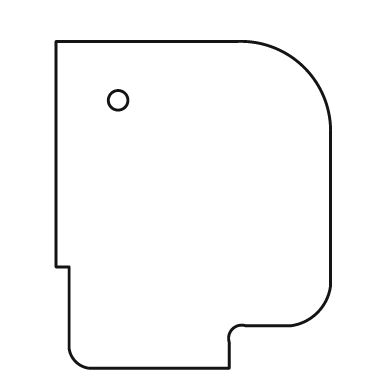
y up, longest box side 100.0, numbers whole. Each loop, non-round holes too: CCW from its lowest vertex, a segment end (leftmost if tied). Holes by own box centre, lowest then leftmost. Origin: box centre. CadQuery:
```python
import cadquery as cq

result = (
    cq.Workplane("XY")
    .moveTo(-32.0, -50.0)
    .lineTo(11.0, -50.0)
    .lineTo(11.0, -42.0)
    .threePointArc((12.0, -38.0), (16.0, -37.0))
    .lineTo(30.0, -37.0)
    .threePointArc((38.0, -33.0), (42.0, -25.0))
    .lineTo(42.0, 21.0)
    .threePointArc((34.0, 42.0), (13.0, 50.0))
    .lineTo(-42.0, 50.0)
    .lineTo(-42.0, -19.0)
    .lineTo(-38.0, -19.0)
    .lineTo(-38.0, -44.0)
    .threePointArc((-36.0, -48.0), (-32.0, -50.0))
    .close()
    .moveTo(-23.0, 32.0)
    .circle(3.0)
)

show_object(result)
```